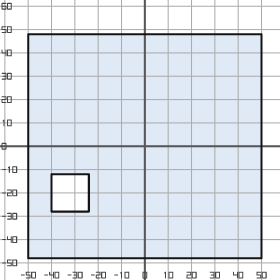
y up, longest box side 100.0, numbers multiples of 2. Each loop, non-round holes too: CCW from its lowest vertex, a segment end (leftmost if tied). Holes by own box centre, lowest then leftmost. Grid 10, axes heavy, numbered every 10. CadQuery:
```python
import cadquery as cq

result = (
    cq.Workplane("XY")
    .moveTo(-50.0, -48.0)
    .lineTo(50.0, -48.0)
    .lineTo(50.0, 48.0)
    .lineTo(-50.0, 48.0)
    .close()
    .moveTo(-40.0, -28.0)
    .lineTo(-24.0, -28.0)
    .lineTo(-24.0, -12.0)
    .lineTo(-40.0, -12.0)
    .close()
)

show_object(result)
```